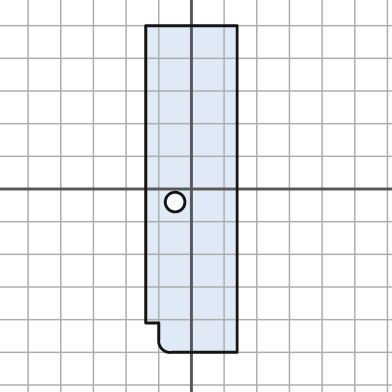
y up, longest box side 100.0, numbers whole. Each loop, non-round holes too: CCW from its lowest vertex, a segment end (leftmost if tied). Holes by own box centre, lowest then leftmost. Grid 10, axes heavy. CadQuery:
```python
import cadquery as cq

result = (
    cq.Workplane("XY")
    .moveTo(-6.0, -50.0)
    .lineTo(14.0, -50.0)
    .lineTo(14.0, 50.0)
    .lineTo(-14.0, 50.0)
    .lineTo(-14.0, -41.0)
    .lineTo(-10.0, -41.0)
    .lineTo(-10.0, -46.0)
    .threePointArc((-9.0, -49.0), (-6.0, -50.0))
    .close()
    .moveTo(-5.0, -4.0)
    .circle(3.0)
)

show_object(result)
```